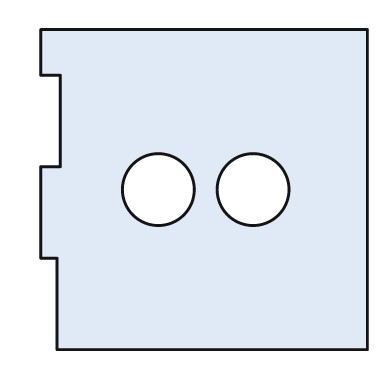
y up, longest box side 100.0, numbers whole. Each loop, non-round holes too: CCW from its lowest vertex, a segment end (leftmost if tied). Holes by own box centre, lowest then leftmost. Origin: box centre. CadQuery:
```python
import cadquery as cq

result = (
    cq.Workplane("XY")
    .moveTo(-45.0, -49.0)
    .lineTo(50.0, -49.0)
    .lineTo(50.0, 49.0)
    .lineTo(-50.0, 49.0)
    .lineTo(-50.0, 35.0)
    .lineTo(-44.0, 35.0)
    .lineTo(-44.0, 7.0)
    .lineTo(-50.0, 7.0)
    .lineTo(-50.0, -21.0)
    .lineTo(-45.0, -21.0)
    .close()
    .moveTo(-14.0, 0.0)
    .circle(11.0)
    .moveTo(15.0, 0.0)
    .circle(11.0)
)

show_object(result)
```